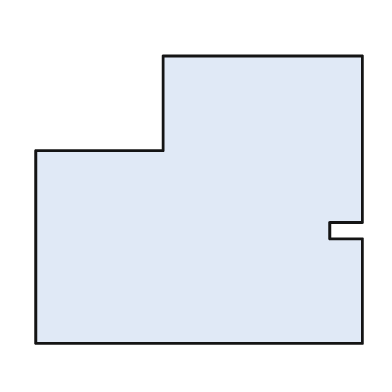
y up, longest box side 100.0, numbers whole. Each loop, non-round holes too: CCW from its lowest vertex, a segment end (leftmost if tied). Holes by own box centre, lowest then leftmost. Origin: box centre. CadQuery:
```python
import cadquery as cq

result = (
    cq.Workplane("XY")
    .moveTo(-50.0, -44.0)
    .lineTo(50.0, -44.0)
    .lineTo(50.0, -12.0)
    .lineTo(40.0, -12.0)
    .lineTo(40.0, -7.0)
    .lineTo(50.0, -7.0)
    .lineTo(50.0, 44.0)
    .lineTo(-11.0, 44.0)
    .lineTo(-11.0, 15.0)
    .lineTo(-50.0, 15.0)
    .close()
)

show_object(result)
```